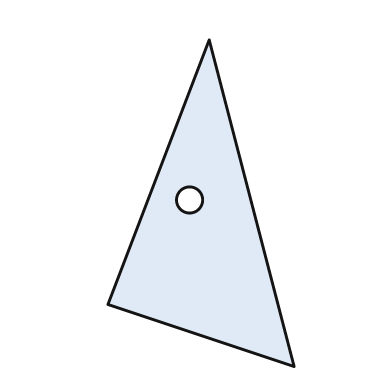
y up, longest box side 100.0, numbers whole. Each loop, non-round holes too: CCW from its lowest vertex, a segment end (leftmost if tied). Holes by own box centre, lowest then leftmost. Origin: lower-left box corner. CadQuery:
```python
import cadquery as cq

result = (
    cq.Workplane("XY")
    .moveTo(57.0, 0.0)
    .lineTo(31.0, 100.0)
    .lineTo(0.0, 19.0)
    .close()
    .moveTo(25.0, 51.0)
    .circle(4.0)
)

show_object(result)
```